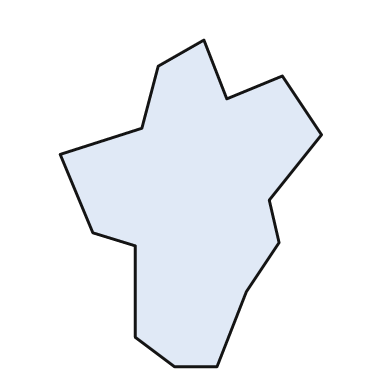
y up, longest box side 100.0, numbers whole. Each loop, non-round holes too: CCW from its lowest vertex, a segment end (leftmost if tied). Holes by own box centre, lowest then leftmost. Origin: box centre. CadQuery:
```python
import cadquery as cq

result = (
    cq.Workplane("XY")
    .moveTo(-5.0, -50.0)
    .lineTo(8.0, -50.0)
    .lineTo(17.0, -27.0)
    .lineTo(27.0, -12.0)
    .lineTo(24.0, 1.0)
    .lineTo(40.0, 21.0)
    .lineTo(28.0, 39.0)
    .lineTo(11.0, 32.0)
    .lineTo(4.0, 50.0)
    .lineTo(-10.0, 42.0)
    .lineTo(-15.0, 23.0)
    .lineTo(-40.0, 15.0)
    .lineTo(-30.0, -9.0)
    .lineTo(-17.0, -13.0)
    .lineTo(-17.0, -41.0)
    .close()
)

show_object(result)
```